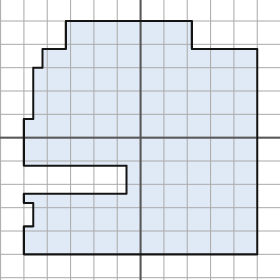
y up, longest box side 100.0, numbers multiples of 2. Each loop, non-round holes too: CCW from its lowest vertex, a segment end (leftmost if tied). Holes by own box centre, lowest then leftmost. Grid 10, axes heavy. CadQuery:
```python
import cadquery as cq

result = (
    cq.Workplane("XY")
    .moveTo(-50.0, -50.0)
    .lineTo(50.0, -50.0)
    .lineTo(50.0, 38.0)
    .lineTo(22.0, 38.0)
    .lineTo(22.0, 50.0)
    .lineTo(-32.0, 50.0)
    .lineTo(-32.0, 38.0)
    .lineTo(-42.0, 38.0)
    .lineTo(-42.0, 30.0)
    .lineTo(-46.0, 30.0)
    .lineTo(-46.0, 8.0)
    .lineTo(-50.0, 8.0)
    .lineTo(-50.0, -12.0)
    .lineTo(-6.0, -12.0)
    .lineTo(-6.0, -24.0)
    .lineTo(-50.0, -24.0)
    .lineTo(-50.0, -28.0)
    .lineTo(-46.0, -28.0)
    .lineTo(-46.0, -38.0)
    .lineTo(-50.0, -38.0)
    .close()
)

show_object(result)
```